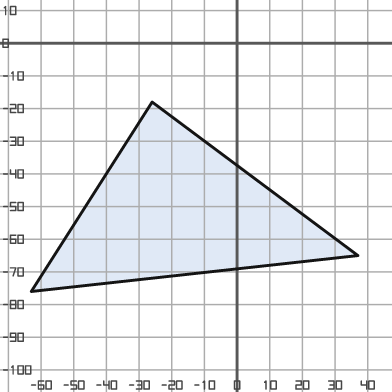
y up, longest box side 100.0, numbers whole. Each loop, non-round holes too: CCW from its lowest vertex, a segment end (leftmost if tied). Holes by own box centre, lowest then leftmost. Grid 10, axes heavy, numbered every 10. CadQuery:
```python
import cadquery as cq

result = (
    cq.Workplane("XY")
    .moveTo(-63.0, -76.0)
    .lineTo(37.0, -65.0)
    .lineTo(-26.0, -18.0)
    .close()
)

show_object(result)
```